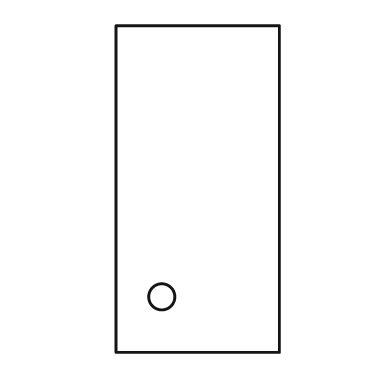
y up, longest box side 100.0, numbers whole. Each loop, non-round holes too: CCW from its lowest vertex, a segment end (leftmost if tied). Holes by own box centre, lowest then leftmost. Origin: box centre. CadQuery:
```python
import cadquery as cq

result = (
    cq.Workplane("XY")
    .moveTo(-25.0, -50.0)
    .lineTo(25.0, -50.0)
    .lineTo(25.0, 50.0)
    .lineTo(-25.0, 50.0)
    .close()
    .moveTo(-11.0, -33.0)
    .circle(4.0)
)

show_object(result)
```